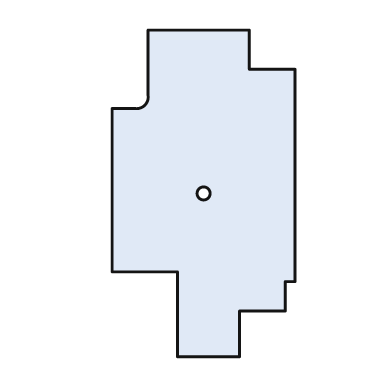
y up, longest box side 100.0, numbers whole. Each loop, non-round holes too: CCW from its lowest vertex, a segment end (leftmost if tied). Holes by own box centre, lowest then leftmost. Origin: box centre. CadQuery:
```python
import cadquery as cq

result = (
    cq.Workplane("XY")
    .moveTo(-8.0, -50.0)
    .lineTo(11.0, -50.0)
    .lineTo(11.0, -36.0)
    .lineTo(25.0, -36.0)
    .lineTo(25.0, -27.0)
    .lineTo(28.0, -27.0)
    .lineTo(28.0, 38.0)
    .lineTo(14.0, 38.0)
    .lineTo(14.0, 50.0)
    .lineTo(-17.0, 50.0)
    .lineTo(-17.0, 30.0)
    .threePointArc((-18.0, 27.0), (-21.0, 26.0))
    .lineTo(-28.0, 26.0)
    .lineTo(-28.0, -24.0)
    .lineTo(-8.0, -24.0)
    .close()
    .moveTo(0.0, 0.0)
    .circle(2.0)
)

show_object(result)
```